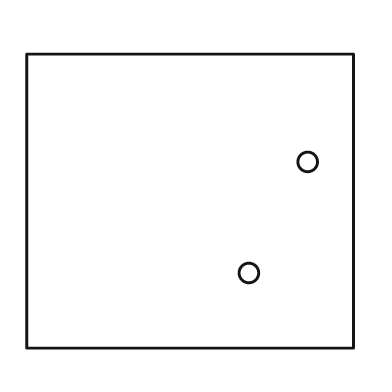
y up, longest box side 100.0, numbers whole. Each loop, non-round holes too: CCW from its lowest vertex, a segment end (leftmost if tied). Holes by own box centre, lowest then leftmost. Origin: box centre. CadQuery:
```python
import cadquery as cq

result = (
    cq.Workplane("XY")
    .moveTo(-50.0, -45.0)
    .lineTo(50.0, -45.0)
    .lineTo(50.0, 45.0)
    .lineTo(-50.0, 45.0)
    .close()
    .moveTo(18.0, -22.0)
    .circle(3.0)
    .moveTo(36.0, 12.0)
    .circle(3.0)
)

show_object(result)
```